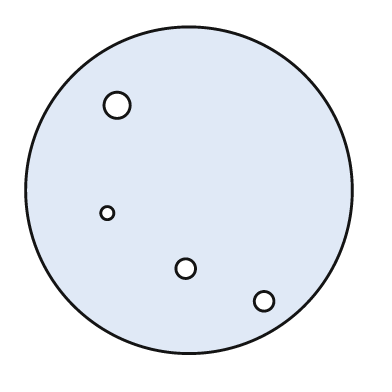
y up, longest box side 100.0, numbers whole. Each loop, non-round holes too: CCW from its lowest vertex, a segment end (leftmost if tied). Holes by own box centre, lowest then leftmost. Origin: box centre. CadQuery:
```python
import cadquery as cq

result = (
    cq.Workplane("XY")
    .moveTo(0.0, 0.0)
    .circle(50.0)
    .moveTo(23.0, -34.0)
    .circle(3.0)
    .moveTo(-1.0, -24.0)
    .circle(3.0)
    .moveTo(-25.0, -7.0)
    .circle(2.0)
    .moveTo(-22.0, 26.0)
    .circle(4.0)
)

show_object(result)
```